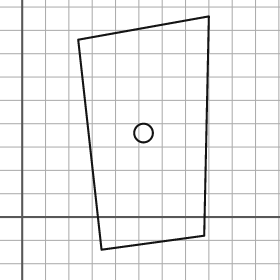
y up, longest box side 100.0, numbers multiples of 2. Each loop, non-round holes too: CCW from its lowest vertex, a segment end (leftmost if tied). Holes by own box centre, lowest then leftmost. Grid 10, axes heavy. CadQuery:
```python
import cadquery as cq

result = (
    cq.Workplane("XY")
    .moveTo(34.0, -14.0)
    .lineTo(78.0, -8.0)
    .lineTo(80.0, 86.0)
    .lineTo(24.0, 76.0)
    .close()
    .moveTo(52.0, 36.0)
    .circle(4.0)
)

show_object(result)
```